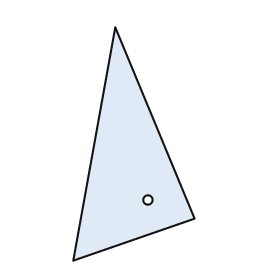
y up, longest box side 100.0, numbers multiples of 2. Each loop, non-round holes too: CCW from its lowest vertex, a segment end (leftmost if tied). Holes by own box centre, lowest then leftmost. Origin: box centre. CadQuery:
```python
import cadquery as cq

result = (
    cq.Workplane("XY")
    .moveTo(-26.0, -50.0)
    .lineTo(26.0, -32.0)
    .lineTo(-8.0, 50.0)
    .close()
    .moveTo(6.0, -24.0)
    .circle(2.0)
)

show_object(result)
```